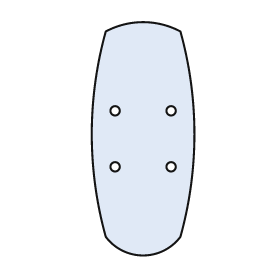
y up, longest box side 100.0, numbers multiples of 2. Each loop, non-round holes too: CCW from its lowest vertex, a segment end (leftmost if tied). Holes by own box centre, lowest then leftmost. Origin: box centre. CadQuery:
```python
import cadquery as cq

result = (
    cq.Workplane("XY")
    .moveTo(-16.0, -42.0)
    .threePointArc((0.0, -50.0), (16.0, -42.0))
    .threePointArc((22.0, 2.0), (16.0, 46.0))
    .threePointArc((0.0, 50.0), (-16.0, 46.0))
    .threePointArc((-22.0, 2.0), (-16.0, -42.0))
    .close()
    .moveTo(-12.0, -12.0)
    .circle(2.0)
    .moveTo(12.0, -12.0)
    .circle(2.0)
    .moveTo(-12.0, 12.0)
    .circle(2.0)
    .moveTo(12.0, 12.0)
    .circle(2.0)
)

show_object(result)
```